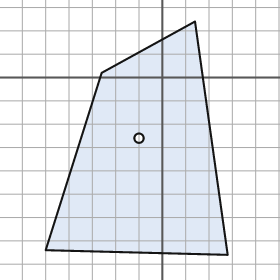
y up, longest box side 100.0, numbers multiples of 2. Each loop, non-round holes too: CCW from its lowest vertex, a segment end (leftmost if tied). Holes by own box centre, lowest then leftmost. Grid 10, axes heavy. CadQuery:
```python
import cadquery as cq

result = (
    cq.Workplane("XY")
    .moveTo(28.0, -76.0)
    .lineTo(14.0, 24.0)
    .lineTo(-26.0, 2.0)
    .lineTo(-50.0, -74.0)
    .close()
    .moveTo(-10.0, -26.0)
    .circle(2.0)
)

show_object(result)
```